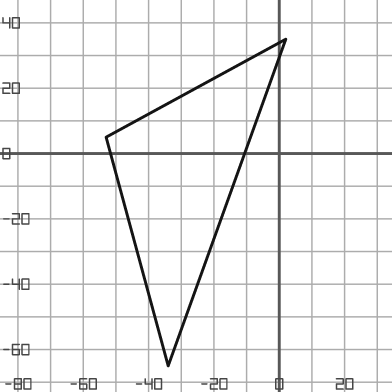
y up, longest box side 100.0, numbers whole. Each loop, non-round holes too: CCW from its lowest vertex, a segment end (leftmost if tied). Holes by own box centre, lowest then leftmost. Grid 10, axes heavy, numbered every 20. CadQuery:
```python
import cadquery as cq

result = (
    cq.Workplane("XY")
    .moveTo(-34.0, -65.0)
    .lineTo(2.0, 35.0)
    .lineTo(-53.0, 5.0)
    .close()
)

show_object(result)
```